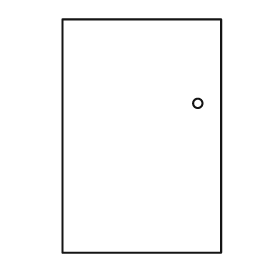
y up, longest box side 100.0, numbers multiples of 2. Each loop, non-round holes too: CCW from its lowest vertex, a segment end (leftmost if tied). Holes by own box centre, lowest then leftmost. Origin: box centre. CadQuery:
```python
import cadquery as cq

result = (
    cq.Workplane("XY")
    .moveTo(-34.0, -50.0)
    .lineTo(34.0, -50.0)
    .lineTo(34.0, 50.0)
    .lineTo(-34.0, 50.0)
    .close()
    .moveTo(24.0, 14.0)
    .circle(2.0)
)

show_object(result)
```